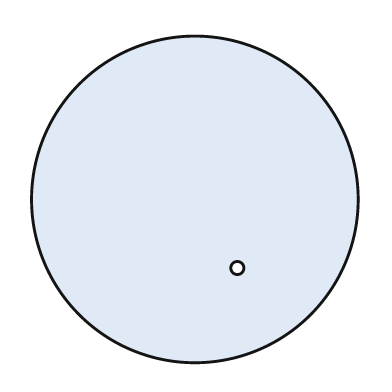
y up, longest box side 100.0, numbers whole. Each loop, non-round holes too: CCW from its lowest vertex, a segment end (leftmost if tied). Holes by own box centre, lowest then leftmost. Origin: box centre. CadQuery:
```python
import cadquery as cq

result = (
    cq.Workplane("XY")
    .moveTo(0.0, 0.0)
    .circle(50.0)
    .moveTo(13.0, -21.0)
    .circle(2.0)
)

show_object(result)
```